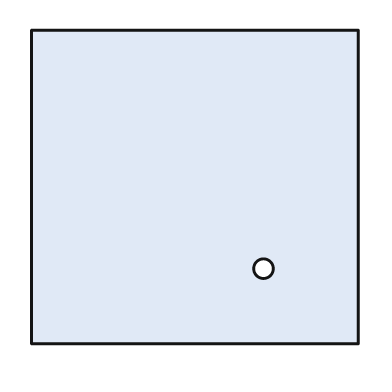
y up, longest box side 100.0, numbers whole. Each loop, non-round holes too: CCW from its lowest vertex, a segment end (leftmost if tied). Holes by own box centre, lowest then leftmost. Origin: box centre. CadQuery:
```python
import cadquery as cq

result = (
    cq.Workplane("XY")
    .moveTo(-50.0, -48.0)
    .lineTo(50.0, -48.0)
    .lineTo(50.0, 48.0)
    .lineTo(-50.0, 48.0)
    .close()
    .moveTo(21.0, -25.0)
    .circle(3.0)
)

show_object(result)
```